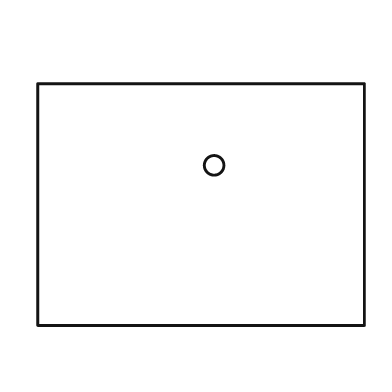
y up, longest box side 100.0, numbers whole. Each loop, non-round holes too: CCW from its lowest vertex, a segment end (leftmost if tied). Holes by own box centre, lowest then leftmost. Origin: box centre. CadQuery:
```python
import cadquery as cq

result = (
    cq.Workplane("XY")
    .moveTo(-50.0, -37.0)
    .lineTo(50.0, -37.0)
    .lineTo(50.0, 37.0)
    .lineTo(-50.0, 37.0)
    .close()
    .moveTo(4.0, 12.0)
    .circle(3.0)
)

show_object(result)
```